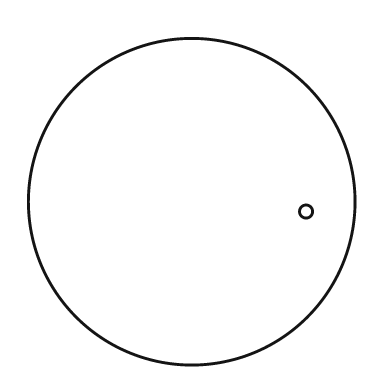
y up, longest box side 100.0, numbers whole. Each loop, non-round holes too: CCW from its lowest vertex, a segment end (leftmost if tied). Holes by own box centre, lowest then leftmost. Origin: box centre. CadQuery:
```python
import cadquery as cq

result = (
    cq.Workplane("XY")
    .moveTo(0.0, 0.0)
    .circle(50.0)
    .moveTo(35.0, -3.0)
    .circle(2.0)
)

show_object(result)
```